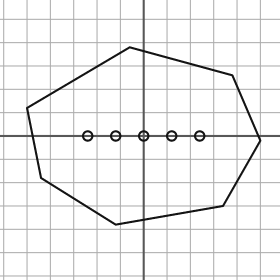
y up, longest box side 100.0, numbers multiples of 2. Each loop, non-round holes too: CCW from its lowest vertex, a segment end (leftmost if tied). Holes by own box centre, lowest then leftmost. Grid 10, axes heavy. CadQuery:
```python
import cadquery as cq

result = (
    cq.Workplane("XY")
    .moveTo(-12.0, -38.0)
    .lineTo(34.0, -30.0)
    .lineTo(50.0, -2.0)
    .lineTo(38.0, 26.0)
    .lineTo(-6.0, 38.0)
    .lineTo(-50.0, 12.0)
    .lineTo(-44.0, -18.0)
    .close()
    .moveTo(-24.0, 0.0)
    .circle(2.0)
    .moveTo(-12.0, 0.0)
    .circle(2.0)
    .moveTo(0.0, 0.0)
    .circle(2.0)
    .moveTo(12.0, 0.0)
    .circle(2.0)
    .moveTo(24.0, 0.0)
    .circle(2.0)
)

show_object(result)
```